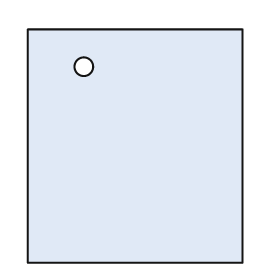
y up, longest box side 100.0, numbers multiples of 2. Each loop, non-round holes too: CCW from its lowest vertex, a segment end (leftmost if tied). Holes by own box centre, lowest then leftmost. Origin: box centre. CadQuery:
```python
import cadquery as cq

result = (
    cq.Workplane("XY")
    .moveTo(-46.0, -50.0)
    .lineTo(46.0, -50.0)
    .lineTo(46.0, 50.0)
    .lineTo(-46.0, 50.0)
    .close()
    .moveTo(-22.0, 34.0)
    .circle(4.0)
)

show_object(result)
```